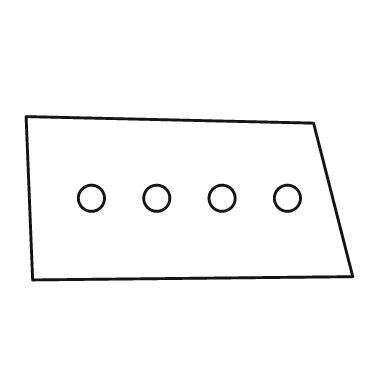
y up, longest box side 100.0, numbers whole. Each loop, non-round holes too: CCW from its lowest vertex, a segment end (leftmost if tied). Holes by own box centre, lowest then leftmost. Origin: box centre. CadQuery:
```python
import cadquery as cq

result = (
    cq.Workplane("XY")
    .moveTo(-48.0, -25.0)
    .lineTo(50.0, -24.0)
    .lineTo(38.0, 23.0)
    .lineTo(-50.0, 25.0)
    .close()
    .moveTo(-30.0, 0.0)
    .circle(4.0)
    .moveTo(-10.0, 0.0)
    .circle(4.0)
    .moveTo(10.0, 0.0)
    .circle(4.0)
    .moveTo(30.0, 0.0)
    .circle(4.0)
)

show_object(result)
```